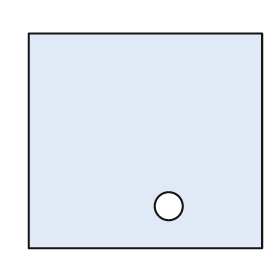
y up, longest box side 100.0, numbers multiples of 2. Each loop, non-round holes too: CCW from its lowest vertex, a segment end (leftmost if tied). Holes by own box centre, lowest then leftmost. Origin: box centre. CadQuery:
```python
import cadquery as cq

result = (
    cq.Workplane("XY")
    .moveTo(-50.0, -46.0)
    .lineTo(50.0, -46.0)
    .lineTo(50.0, 46.0)
    .lineTo(-50.0, 46.0)
    .close()
    .moveTo(10.0, -28.0)
    .circle(6.0)
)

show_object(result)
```